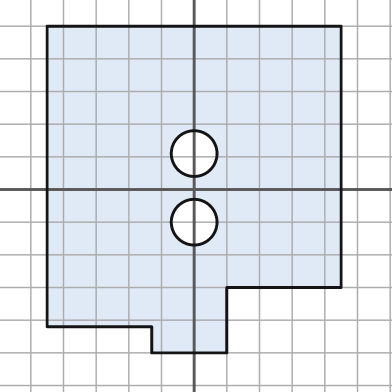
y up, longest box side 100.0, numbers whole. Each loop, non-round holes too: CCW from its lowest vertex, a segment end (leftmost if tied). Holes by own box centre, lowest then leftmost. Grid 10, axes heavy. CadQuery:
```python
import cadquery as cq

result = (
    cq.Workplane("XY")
    .moveTo(-13.0, -50.0)
    .lineTo(10.0, -50.0)
    .lineTo(10.0, -30.0)
    .lineTo(45.0, -30.0)
    .lineTo(45.0, 50.0)
    .lineTo(-45.0, 50.0)
    .lineTo(-45.0, -42.0)
    .lineTo(-13.0, -42.0)
    .close()
    .moveTo(0.0, -10.0)
    .circle(7.0)
    .moveTo(0.0, 11.0)
    .circle(7.0)
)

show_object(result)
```